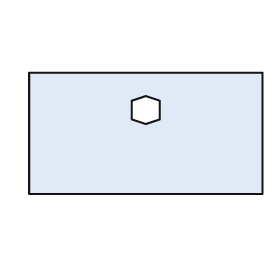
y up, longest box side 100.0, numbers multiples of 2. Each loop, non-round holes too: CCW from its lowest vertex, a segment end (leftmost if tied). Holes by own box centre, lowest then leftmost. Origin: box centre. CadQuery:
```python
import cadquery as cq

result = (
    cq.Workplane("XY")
    .moveTo(-50.0, -26.0)
    .lineTo(50.0, -26.0)
    .lineTo(50.0, 26.0)
    .lineTo(-50.0, 26.0)
    .close()
    .moveTo(0.0, 4.0)
    .lineTo(6.0, 6.0)
    .lineTo(6.0, 14.0)
    .lineTo(0.0, 16.0)
    .lineTo(-6.0, 14.0)
    .lineTo(-6.0, 6.0)
    .close()
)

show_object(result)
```